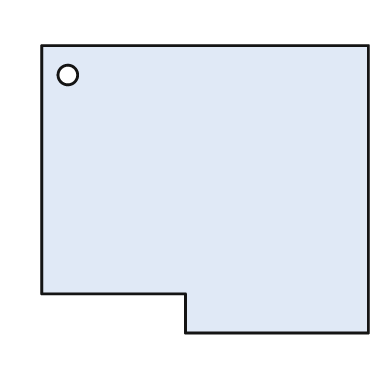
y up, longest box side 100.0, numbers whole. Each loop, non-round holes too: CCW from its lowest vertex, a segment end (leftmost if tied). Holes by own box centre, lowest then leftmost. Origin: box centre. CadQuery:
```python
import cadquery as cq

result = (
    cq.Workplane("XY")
    .moveTo(-6.0, -44.0)
    .lineTo(50.0, -44.0)
    .lineTo(50.0, 44.0)
    .lineTo(-50.0, 44.0)
    .lineTo(-50.0, -32.0)
    .lineTo(-6.0, -32.0)
    .close()
    .moveTo(-42.0, 35.0)
    .circle(3.0)
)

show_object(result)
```